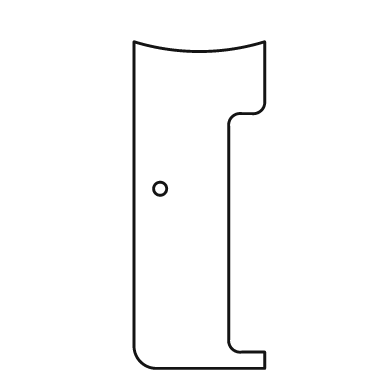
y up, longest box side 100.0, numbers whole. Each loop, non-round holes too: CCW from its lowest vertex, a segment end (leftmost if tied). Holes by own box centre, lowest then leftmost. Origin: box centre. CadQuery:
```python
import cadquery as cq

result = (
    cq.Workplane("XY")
    .moveTo(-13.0, -50.0)
    .lineTo(20.0, -50.0)
    .lineTo(20.0, -45.0)
    .lineTo(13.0, -45.0)
    .threePointArc((10.0, -44.0), (9.0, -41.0))
    .lineTo(9.0, 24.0)
    .threePointArc((10.0, 27.0), (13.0, 28.0))
    .lineTo(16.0, 28.0)
    .threePointArc((19.0, 29.0), (20.0, 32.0))
    .lineTo(20.0, 50.0)
    .threePointArc((0.0, 47.0), (-20.0, 50.0))
    .lineTo(-20.0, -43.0)
    .threePointArc((-18.0, -48.0), (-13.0, -50.0))
    .close()
    .moveTo(-12.0, 5.0)
    .circle(2.0)
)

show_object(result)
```